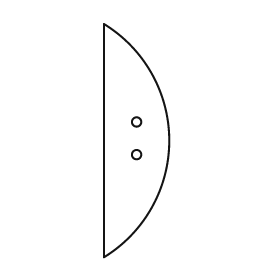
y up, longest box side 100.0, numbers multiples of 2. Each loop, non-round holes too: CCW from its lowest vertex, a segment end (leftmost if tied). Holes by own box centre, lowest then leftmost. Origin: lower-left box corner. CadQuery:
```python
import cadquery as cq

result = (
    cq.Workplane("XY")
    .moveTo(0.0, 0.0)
    .threePointArc((28.0, 50.0), (0.0, 100.0))
    .close()
    .moveTo(14.0, 44.0)
    .circle(2.0)
    .moveTo(14.0, 58.0)
    .circle(2.0)
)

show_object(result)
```